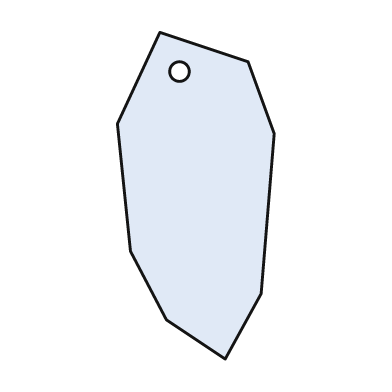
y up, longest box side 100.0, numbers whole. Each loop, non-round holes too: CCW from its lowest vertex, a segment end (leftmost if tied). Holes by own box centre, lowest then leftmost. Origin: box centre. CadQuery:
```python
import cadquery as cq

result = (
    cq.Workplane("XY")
    .moveTo(9.0, -50.0)
    .lineTo(20.0, -30.0)
    .lineTo(24.0, 19.0)
    .lineTo(16.0, 41.0)
    .lineTo(-11.0, 50.0)
    .lineTo(-24.0, 22.0)
    .lineTo(-20.0, -17.0)
    .lineTo(-9.0, -38.0)
    .close()
    .moveTo(-5.0, 38.0)
    .circle(3.0)
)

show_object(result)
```